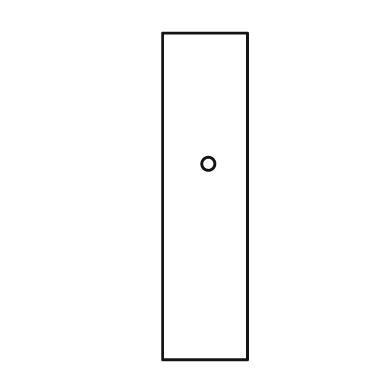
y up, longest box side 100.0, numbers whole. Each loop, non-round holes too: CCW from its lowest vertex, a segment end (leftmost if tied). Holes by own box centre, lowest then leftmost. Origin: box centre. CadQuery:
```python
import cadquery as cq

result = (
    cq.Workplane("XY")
    .moveTo(-13.0, -50.0)
    .lineTo(13.0, -50.0)
    .lineTo(13.0, 50.0)
    .lineTo(-13.0, 50.0)
    .close()
    .moveTo(1.0, 10.0)
    .circle(2.0)
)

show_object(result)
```